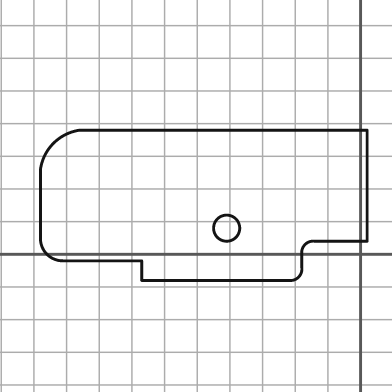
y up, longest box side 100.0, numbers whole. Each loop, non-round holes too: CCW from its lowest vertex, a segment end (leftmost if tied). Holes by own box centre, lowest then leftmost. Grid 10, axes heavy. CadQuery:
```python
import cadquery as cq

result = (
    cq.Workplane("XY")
    .moveTo(-67.0, -8.0)
    .lineTo(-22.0, -8.0)
    .threePointArc((-19.0, -7.0), (-18.0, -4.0))
    .lineTo(-18.0, 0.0)
    .threePointArc((-17.0, 3.0), (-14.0, 4.0))
    .lineTo(2.0, 4.0)
    .lineTo(2.0, 38.0)
    .lineTo(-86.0, 38.0)
    .threePointArc((-94.0, 34.0), (-98.0, 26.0))
    .lineTo(-98.0, 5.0)
    .threePointArc((-96.0, 0.0), (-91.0, -2.0))
    .lineTo(-67.0, -2.0)
    .close()
    .moveTo(-41.0, 8.0)
    .circle(4.0)
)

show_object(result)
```